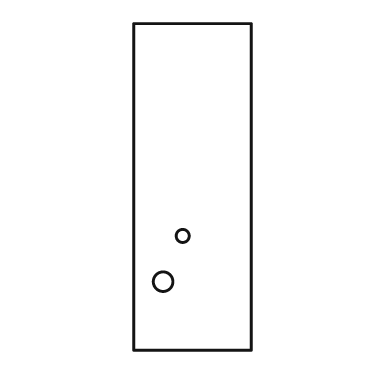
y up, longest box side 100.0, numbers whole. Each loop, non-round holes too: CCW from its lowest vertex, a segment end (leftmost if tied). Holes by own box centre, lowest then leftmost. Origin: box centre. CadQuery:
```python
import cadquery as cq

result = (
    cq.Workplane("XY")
    .moveTo(-18.0, -50.0)
    .lineTo(18.0, -50.0)
    .lineTo(18.0, 50.0)
    .lineTo(-18.0, 50.0)
    .close()
    .moveTo(-9.0, -29.0)
    .circle(3.0)
    .moveTo(-3.0, -15.0)
    .circle(2.0)
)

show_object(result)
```